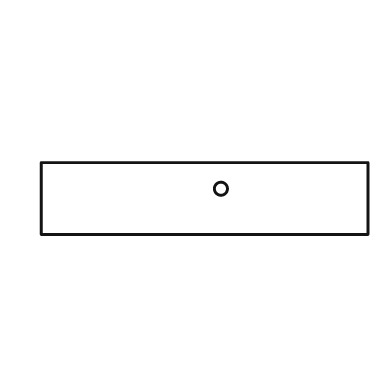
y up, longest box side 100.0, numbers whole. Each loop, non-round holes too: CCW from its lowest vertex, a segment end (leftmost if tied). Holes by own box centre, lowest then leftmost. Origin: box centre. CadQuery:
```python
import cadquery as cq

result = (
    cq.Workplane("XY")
    .moveTo(-50.0, -11.0)
    .lineTo(50.0, -11.0)
    .lineTo(50.0, 11.0)
    .lineTo(-50.0, 11.0)
    .close()
    .moveTo(5.0, 3.0)
    .circle(2.0)
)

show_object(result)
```